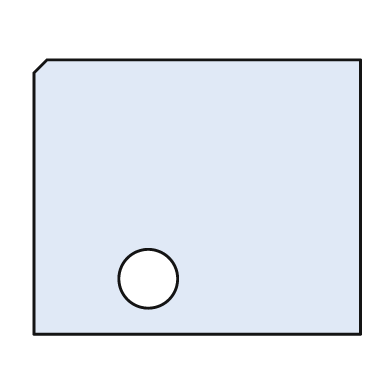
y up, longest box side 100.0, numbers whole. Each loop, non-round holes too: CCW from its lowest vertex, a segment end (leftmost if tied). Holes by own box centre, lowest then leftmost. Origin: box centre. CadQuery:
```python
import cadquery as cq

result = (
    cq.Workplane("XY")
    .moveTo(-50.0, -42.0)
    .lineTo(50.0, -42.0)
    .lineTo(50.0, 42.0)
    .lineTo(-46.0, 42.0)
    .lineTo(-50.0, 38.0)
    .close()
    .moveTo(-15.0, -25.0)
    .circle(9.0)
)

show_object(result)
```